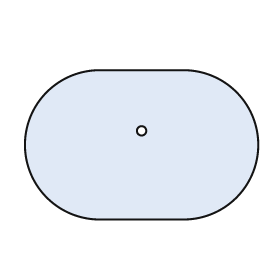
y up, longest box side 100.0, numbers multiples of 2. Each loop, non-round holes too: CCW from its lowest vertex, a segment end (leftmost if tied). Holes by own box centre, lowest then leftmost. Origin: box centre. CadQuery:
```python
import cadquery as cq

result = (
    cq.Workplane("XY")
    .moveTo(-18.0, -32.0)
    .lineTo(18.0, -32.0)
    .threePointArc((50.0, 0.0), (18.0, 32.0))
    .lineTo(-18.0, 32.0)
    .threePointArc((-50.0, 0.0), (-18.0, -32.0))
    .close()
    .moveTo(0.0, 6.0)
    .circle(2.0)
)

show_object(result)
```